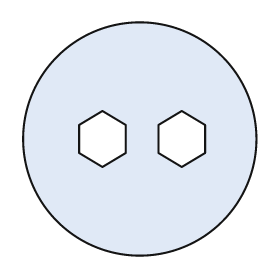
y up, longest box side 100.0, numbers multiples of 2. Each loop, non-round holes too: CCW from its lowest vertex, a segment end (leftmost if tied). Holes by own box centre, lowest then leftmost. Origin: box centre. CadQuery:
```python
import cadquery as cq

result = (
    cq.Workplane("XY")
    .moveTo(0.0, 0.0)
    .circle(50.0)
    .moveTo(-16.0, -12.0)
    .lineTo(-6.0, -6.0)
    .lineTo(-6.0, 6.0)
    .lineTo(-16.0, 12.0)
    .lineTo(-26.0, 6.0)
    .lineTo(-26.0, -6.0)
    .close()
    .moveTo(18.0, -12.0)
    .lineTo(28.0, -6.0)
    .lineTo(28.0, 6.0)
    .lineTo(18.0, 12.0)
    .lineTo(8.0, 6.0)
    .lineTo(8.0, -6.0)
    .close()
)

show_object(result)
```